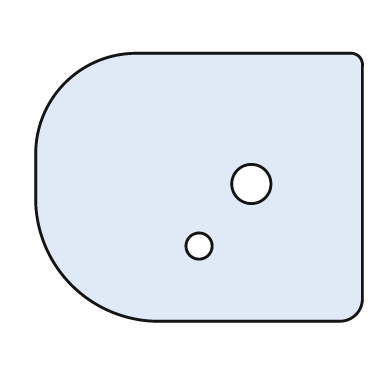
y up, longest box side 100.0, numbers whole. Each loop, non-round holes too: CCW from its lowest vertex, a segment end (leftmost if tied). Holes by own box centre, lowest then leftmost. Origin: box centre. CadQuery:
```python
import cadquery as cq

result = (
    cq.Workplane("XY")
    .moveTo(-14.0, -41.0)
    .lineTo(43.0, -41.0)
    .threePointArc((48.0, -39.0), (50.0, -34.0))
    .lineTo(50.0, 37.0)
    .threePointArc((49.0, 40.0), (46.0, 41.0))
    .lineTo(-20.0, 41.0)
    .threePointArc((-41.0, 32.0), (-50.0, 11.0))
    .lineTo(-50.0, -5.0)
    .threePointArc((-39.0, -30.0), (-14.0, -41.0))
    .close()
    .moveTo(0.0, -18.0)
    .circle(4.0)
    .moveTo(16.0, 1.0)
    .circle(6.0)
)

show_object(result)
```